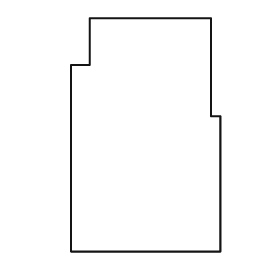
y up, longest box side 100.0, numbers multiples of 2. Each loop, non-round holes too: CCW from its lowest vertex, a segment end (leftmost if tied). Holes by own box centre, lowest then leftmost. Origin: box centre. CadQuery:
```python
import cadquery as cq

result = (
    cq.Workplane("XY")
    .moveTo(-32.0, -50.0)
    .lineTo(32.0, -50.0)
    .lineTo(32.0, 8.0)
    .lineTo(28.0, 8.0)
    .lineTo(28.0, 50.0)
    .lineTo(-24.0, 50.0)
    .lineTo(-24.0, 30.0)
    .lineTo(-32.0, 30.0)
    .close()
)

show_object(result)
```